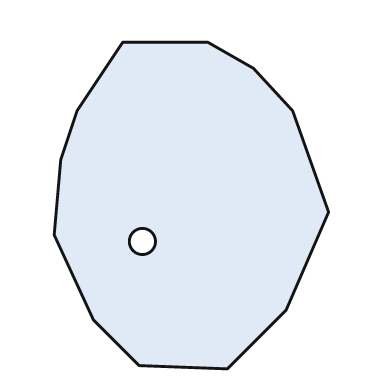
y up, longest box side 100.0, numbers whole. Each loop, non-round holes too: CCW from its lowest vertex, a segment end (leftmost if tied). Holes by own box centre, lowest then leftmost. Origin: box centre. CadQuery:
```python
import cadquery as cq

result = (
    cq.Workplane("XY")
    .moveTo(11.0, -50.0)
    .lineTo(29.0, -32.0)
    .lineTo(42.0, -2.0)
    .lineTo(31.0, 29.0)
    .lineTo(19.0, 42.0)
    .lineTo(5.0, 50.0)
    .lineTo(-21.0, 50.0)
    .lineTo(-35.0, 29.0)
    .lineTo(-40.0, 14.0)
    .lineTo(-42.0, -9.0)
    .lineTo(-30.0, -35.0)
    .lineTo(-16.0, -49.0)
    .close()
    .moveTo(-15.0, -11.0)
    .circle(4.0)
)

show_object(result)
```